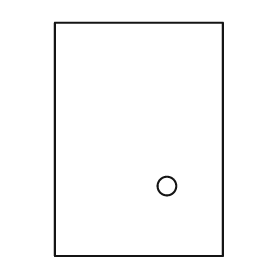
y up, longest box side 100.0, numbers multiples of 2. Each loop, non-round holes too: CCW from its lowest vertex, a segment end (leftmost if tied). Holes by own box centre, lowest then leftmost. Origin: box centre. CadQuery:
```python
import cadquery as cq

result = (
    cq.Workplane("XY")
    .moveTo(-36.0, -50.0)
    .lineTo(36.0, -50.0)
    .lineTo(36.0, 50.0)
    .lineTo(-36.0, 50.0)
    .close()
    .moveTo(12.0, -20.0)
    .circle(4.0)
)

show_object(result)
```